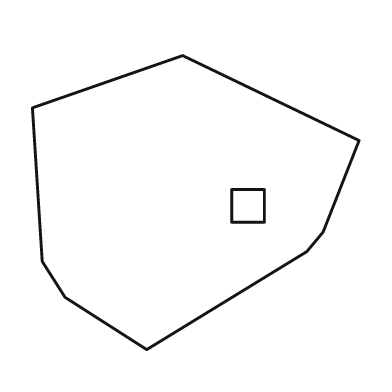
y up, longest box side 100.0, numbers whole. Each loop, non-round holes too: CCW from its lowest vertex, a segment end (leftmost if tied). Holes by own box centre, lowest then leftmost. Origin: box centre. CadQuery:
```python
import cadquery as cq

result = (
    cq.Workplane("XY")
    .moveTo(-15.0, -45.0)
    .lineTo(34.0, -15.0)
    .lineTo(39.0, -9.0)
    .lineTo(50.0, 19.0)
    .lineTo(-4.0, 45.0)
    .lineTo(-50.0, 29.0)
    .lineTo(-47.0, -18.0)
    .lineTo(-40.0, -29.0)
    .close()
    .moveTo(11.0, -6.0)
    .lineTo(21.0, -6.0)
    .lineTo(21.0, 4.0)
    .lineTo(11.0, 4.0)
    .close()
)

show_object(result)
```